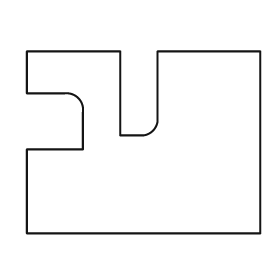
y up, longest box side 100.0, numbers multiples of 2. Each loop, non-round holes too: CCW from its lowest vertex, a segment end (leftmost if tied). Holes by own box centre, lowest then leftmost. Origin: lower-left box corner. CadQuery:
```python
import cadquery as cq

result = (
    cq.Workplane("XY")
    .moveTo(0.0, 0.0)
    .lineTo(100.0, 0.0)
    .lineTo(100.0, 78.0)
    .lineTo(56.0, 78.0)
    .lineTo(56.0, 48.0)
    .threePointArc((54.0, 44.0), (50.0, 42.0))
    .lineTo(40.0, 42.0)
    .lineTo(40.0, 78.0)
    .lineTo(0.0, 78.0)
    .lineTo(0.0, 60.0)
    .lineTo(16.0, 60.0)
    .threePointArc((22.0, 58.0), (24.0, 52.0))
    .lineTo(24.0, 36.0)
    .lineTo(0.0, 36.0)
    .close()
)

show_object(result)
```